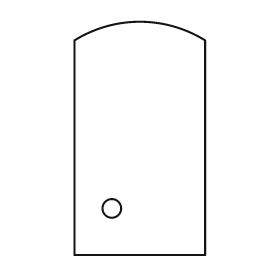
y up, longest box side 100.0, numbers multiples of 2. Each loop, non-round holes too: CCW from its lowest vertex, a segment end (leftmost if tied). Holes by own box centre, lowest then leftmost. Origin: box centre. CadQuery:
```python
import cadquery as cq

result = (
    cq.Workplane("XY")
    .moveTo(-28.0, -50.0)
    .lineTo(28.0, -50.0)
    .lineTo(28.0, 42.0)
    .threePointArc((0.0, 50.0), (-28.0, 42.0))
    .close()
    .moveTo(-12.0, -30.0)
    .circle(4.0)
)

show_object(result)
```